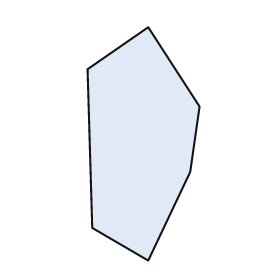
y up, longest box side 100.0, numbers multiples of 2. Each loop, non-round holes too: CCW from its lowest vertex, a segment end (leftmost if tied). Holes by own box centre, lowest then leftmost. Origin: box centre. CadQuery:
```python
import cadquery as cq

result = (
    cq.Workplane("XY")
    .moveTo(2.0, -50.0)
    .lineTo(20.0, -12.0)
    .lineTo(24.0, 16.0)
    .lineTo(2.0, 50.0)
    .lineTo(-24.0, 32.0)
    .lineTo(-22.0, -36.0)
    .close()
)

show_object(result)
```